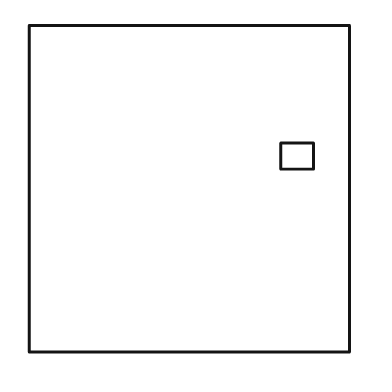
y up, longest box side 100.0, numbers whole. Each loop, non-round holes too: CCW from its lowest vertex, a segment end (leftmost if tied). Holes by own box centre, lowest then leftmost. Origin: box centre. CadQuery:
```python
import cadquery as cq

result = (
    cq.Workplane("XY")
    .moveTo(-49.0, -50.0)
    .lineTo(49.0, -50.0)
    .lineTo(49.0, 50.0)
    .lineTo(-49.0, 50.0)
    .close()
    .moveTo(28.0, 6.0)
    .lineTo(38.0, 6.0)
    .lineTo(38.0, 14.0)
    .lineTo(28.0, 14.0)
    .close()
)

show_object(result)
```